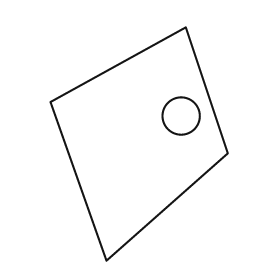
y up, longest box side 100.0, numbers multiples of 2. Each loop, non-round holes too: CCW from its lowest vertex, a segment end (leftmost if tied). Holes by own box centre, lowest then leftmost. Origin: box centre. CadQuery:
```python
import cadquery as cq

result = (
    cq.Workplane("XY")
    .moveTo(-14.0, -50.0)
    .lineTo(38.0, -4.0)
    .lineTo(20.0, 50.0)
    .lineTo(-38.0, 18.0)
    .close()
    .moveTo(18.0, 12.0)
    .circle(8.0)
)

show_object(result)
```